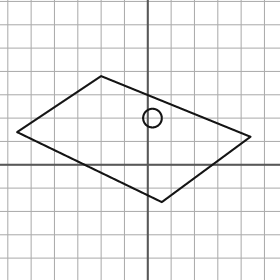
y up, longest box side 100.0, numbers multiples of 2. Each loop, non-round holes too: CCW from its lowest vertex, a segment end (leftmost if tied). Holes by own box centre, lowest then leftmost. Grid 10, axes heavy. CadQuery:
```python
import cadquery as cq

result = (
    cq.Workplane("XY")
    .moveTo(6.0, -16.0)
    .lineTo(44.0, 12.0)
    .lineTo(-20.0, 38.0)
    .lineTo(-56.0, 14.0)
    .close()
    .moveTo(2.0, 20.0)
    .circle(4.0)
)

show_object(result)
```